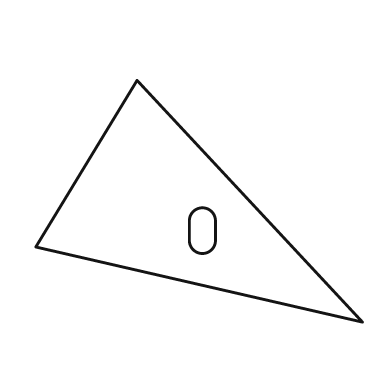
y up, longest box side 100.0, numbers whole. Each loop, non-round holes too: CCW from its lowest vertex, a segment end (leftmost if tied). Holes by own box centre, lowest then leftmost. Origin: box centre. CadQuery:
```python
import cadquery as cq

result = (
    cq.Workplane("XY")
    .moveTo(50.0, -37.0)
    .lineTo(-19.0, 37.0)
    .lineTo(-50.0, -14.0)
    .close()
    .moveTo(-3.0, -12.0)
    .threePointArc((1.0, -16.0), (5.0, -12.0))
    .lineTo(5.0, -6.0)
    .threePointArc((1.0, -2.0), (-3.0, -6.0))
    .close()
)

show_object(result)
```